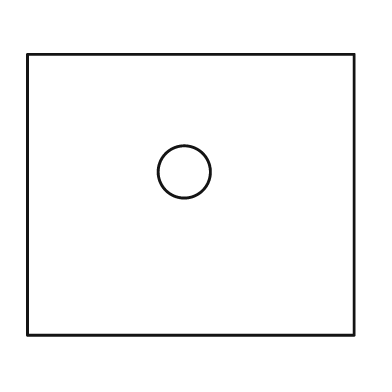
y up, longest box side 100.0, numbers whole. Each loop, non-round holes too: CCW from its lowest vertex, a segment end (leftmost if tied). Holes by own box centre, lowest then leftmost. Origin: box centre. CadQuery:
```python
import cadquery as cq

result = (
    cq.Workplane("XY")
    .moveTo(-50.0, -43.0)
    .lineTo(50.0, -43.0)
    .lineTo(50.0, 43.0)
    .lineTo(-50.0, 43.0)
    .close()
    .moveTo(-2.0, 7.0)
    .circle(8.0)
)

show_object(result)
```